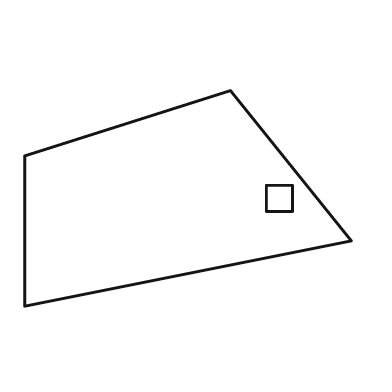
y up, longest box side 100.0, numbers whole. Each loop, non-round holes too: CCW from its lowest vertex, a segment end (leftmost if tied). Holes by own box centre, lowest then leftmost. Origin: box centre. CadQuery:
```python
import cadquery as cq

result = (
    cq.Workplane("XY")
    .moveTo(-50.0, -33.0)
    .lineTo(50.0, -13.0)
    .lineTo(13.0, 33.0)
    .lineTo(-50.0, 13.0)
    .close()
    .moveTo(24.0, -4.0)
    .lineTo(32.0, -4.0)
    .lineTo(32.0, 4.0)
    .lineTo(24.0, 4.0)
    .close()
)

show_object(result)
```